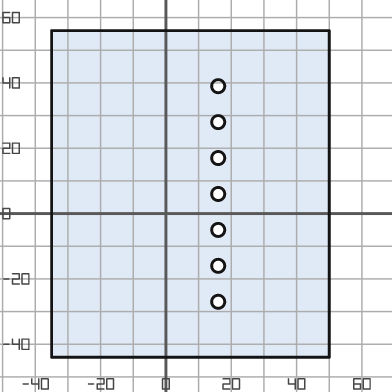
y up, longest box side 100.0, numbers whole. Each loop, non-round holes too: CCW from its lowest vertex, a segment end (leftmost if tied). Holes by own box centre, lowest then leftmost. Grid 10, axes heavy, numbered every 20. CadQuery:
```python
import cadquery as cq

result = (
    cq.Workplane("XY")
    .moveTo(-35.0, -44.0)
    .lineTo(50.0, -44.0)
    .lineTo(50.0, 56.0)
    .lineTo(-35.0, 56.0)
    .close()
    .moveTo(16.0, -27.0)
    .circle(2.0)
    .moveTo(16.0, -16.0)
    .circle(2.0)
    .moveTo(16.0, -5.0)
    .circle(2.0)
    .moveTo(16.0, 6.0)
    .circle(2.0)
    .moveTo(16.0, 17.0)
    .circle(2.0)
    .moveTo(16.0, 28.0)
    .circle(2.0)
    .moveTo(16.0, 39.0)
    .circle(2.0)
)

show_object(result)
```